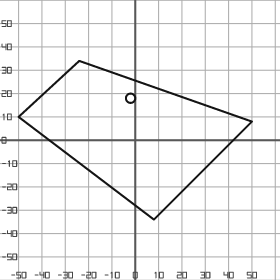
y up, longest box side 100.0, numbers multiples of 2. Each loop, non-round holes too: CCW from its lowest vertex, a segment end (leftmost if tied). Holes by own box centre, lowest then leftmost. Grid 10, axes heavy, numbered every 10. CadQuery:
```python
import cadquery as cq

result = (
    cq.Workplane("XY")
    .moveTo(8.0, -34.0)
    .lineTo(50.0, 8.0)
    .lineTo(-24.0, 34.0)
    .lineTo(-50.0, 10.0)
    .close()
    .moveTo(-2.0, 18.0)
    .circle(2.0)
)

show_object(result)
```